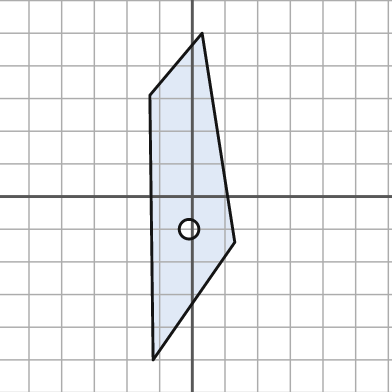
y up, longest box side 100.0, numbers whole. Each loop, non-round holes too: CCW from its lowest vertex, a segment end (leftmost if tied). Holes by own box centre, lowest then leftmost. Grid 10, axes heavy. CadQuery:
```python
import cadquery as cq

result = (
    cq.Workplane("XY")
    .moveTo(-12.0, -50.0)
    .lineTo(13.0, -14.0)
    .lineTo(3.0, 50.0)
    .lineTo(-13.0, 31.0)
    .close()
    .moveTo(-1.0, -10.0)
    .circle(3.0)
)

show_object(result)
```